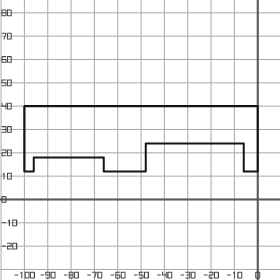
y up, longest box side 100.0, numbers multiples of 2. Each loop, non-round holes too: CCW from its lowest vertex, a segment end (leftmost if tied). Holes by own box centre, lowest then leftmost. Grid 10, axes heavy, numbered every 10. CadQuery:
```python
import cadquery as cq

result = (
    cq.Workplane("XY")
    .moveTo(-100.0, 12.0)
    .lineTo(-96.0, 12.0)
    .lineTo(-96.0, 18.0)
    .lineTo(-66.0, 18.0)
    .lineTo(-66.0, 12.0)
    .lineTo(-48.0, 12.0)
    .lineTo(-48.0, 24.0)
    .lineTo(-6.0, 24.0)
    .lineTo(-6.0, 12.0)
    .lineTo(0.0, 12.0)
    .lineTo(0.0, 40.0)
    .lineTo(-100.0, 40.0)
    .close()
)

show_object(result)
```